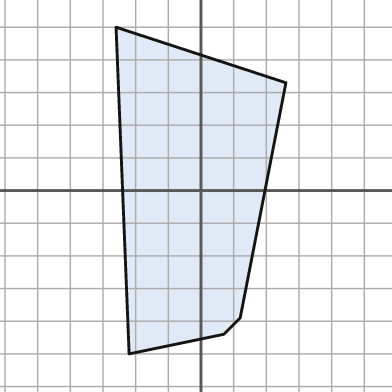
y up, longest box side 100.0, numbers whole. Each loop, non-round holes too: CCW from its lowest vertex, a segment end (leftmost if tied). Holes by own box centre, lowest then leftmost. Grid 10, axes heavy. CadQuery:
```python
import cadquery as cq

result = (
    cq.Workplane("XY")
    .moveTo(-22.0, -50.0)
    .lineTo(7.0, -44.0)
    .lineTo(12.0, -39.0)
    .lineTo(26.0, 33.0)
    .lineTo(-26.0, 50.0)
    .close()
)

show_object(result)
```